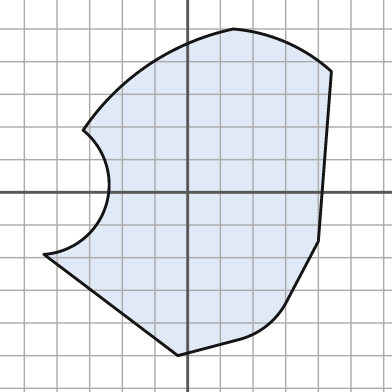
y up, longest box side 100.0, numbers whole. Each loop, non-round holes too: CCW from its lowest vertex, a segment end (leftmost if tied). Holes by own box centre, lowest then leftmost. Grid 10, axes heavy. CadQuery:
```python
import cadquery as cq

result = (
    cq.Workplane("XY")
    .moveTo(-3.0, -50.0)
    .lineTo(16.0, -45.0)
    .threePointArc((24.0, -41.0), (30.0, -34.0))
    .lineTo(40.0, -15.0)
    .lineTo(44.0, 37.0)
    .threePointArc((30.0, 46.0), (14.0, 50.0))
    .threePointArc((-12.0, 39.0), (-32.0, 19.0))
    .threePointArc((-25.0, -4.0), (-44.0, -19.0))
    .close()
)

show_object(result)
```